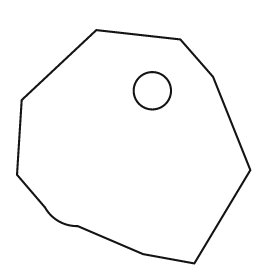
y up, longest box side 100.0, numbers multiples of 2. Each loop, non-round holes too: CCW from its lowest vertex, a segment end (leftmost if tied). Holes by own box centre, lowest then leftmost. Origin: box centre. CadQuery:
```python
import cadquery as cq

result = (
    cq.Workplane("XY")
    .moveTo(26.0, -50.0)
    .lineTo(50.0, -10.0)
    .lineTo(34.0, 30.0)
    .lineTo(20.0, 46.0)
    .lineTo(-16.0, 50.0)
    .lineTo(-48.0, 20.0)
    .lineTo(-50.0, -12.0)
    .lineTo(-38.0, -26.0)
    .threePointArc((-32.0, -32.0), (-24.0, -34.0))
    .lineTo(4.0, -46.0)
    .close()
    .moveTo(8.0, 24.0)
    .circle(8.0)
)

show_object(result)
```